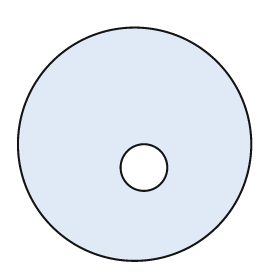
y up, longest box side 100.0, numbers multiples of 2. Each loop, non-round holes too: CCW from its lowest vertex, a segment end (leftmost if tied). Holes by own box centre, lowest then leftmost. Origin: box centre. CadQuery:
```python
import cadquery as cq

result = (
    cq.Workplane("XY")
    .moveTo(0.0, 0.0)
    .circle(50.0)
    .moveTo(4.0, -10.0)
    .circle(10.0)
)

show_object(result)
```